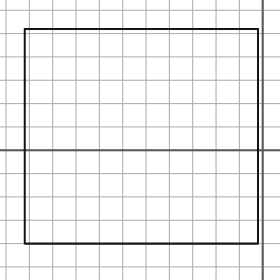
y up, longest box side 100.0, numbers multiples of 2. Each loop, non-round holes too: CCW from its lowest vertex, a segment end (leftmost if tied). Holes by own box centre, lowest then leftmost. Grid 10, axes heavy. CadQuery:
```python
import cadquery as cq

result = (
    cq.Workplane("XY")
    .moveTo(-102.0, -40.0)
    .lineTo(-2.0, -40.0)
    .lineTo(-2.0, 52.0)
    .lineTo(-102.0, 52.0)
    .close()
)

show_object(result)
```